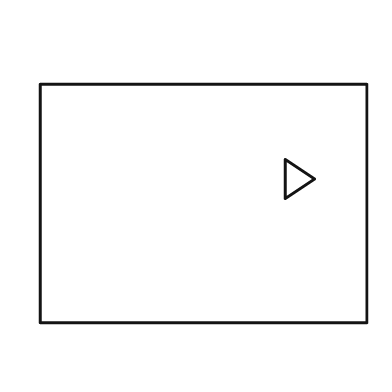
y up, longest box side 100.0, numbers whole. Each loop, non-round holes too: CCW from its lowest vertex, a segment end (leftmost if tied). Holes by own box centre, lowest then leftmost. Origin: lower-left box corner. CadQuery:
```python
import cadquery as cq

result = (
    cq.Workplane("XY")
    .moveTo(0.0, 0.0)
    .lineTo(100.0, 0.0)
    .lineTo(100.0, 73.0)
    .lineTo(0.0, 73.0)
    .close()
    .moveTo(75.0, 38.0)
    .lineTo(84.0, 44.0)
    .lineTo(75.0, 50.0)
    .close()
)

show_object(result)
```